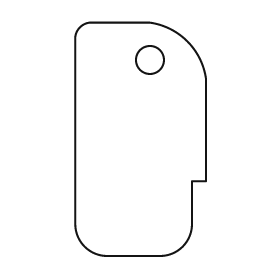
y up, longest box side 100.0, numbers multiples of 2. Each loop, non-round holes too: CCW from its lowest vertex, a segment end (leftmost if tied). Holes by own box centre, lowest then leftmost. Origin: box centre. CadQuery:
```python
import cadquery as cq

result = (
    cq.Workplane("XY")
    .moveTo(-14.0, -50.0)
    .lineTo(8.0, -50.0)
    .threePointArc((18.0, -46.0), (22.0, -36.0))
    .lineTo(22.0, -18.0)
    .lineTo(28.0, -18.0)
    .lineTo(28.0, 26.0)
    .threePointArc((20.0, 42.0), (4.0, 50.0))
    .lineTo(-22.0, 50.0)
    .threePointArc((-26.0, 48.0), (-28.0, 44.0))
    .lineTo(-28.0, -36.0)
    .threePointArc((-24.0, -46.0), (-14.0, -50.0))
    .close()
    .moveTo(4.0, 34.0)
    .circle(6.0)
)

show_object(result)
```